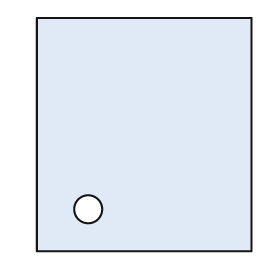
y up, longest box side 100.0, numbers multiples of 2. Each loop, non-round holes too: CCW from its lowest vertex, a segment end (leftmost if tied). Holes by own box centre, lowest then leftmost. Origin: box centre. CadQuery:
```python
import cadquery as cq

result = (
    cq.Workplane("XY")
    .moveTo(-46.0, -50.0)
    .lineTo(46.0, -50.0)
    .lineTo(46.0, 50.0)
    .lineTo(-46.0, 50.0)
    .close()
    .moveTo(-24.0, -32.0)
    .circle(6.0)
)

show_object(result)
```